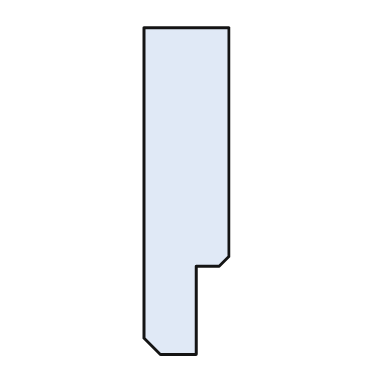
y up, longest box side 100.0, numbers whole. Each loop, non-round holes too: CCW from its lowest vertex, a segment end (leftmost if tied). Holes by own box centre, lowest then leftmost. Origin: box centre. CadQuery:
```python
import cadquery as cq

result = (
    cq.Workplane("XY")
    .moveTo(-8.0, -50.0)
    .lineTo(3.0, -50.0)
    .lineTo(3.0, -23.0)
    .lineTo(10.0, -23.0)
    .lineTo(13.0, -20.0)
    .lineTo(13.0, 50.0)
    .lineTo(-13.0, 50.0)
    .lineTo(-13.0, -45.0)
    .close()
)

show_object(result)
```